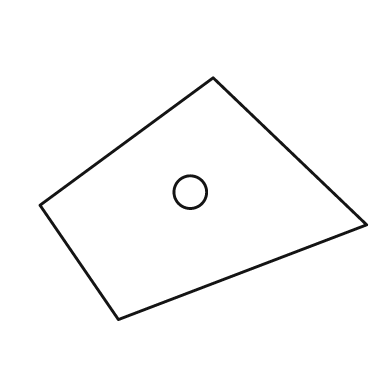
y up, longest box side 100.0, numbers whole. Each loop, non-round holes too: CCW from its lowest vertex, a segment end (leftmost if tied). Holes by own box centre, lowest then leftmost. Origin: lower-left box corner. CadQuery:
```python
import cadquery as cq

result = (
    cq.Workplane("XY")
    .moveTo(24.0, 0.0)
    .lineTo(100.0, 29.0)
    .lineTo(53.0, 74.0)
    .lineTo(0.0, 35.0)
    .close()
    .moveTo(46.0, 39.0)
    .circle(5.0)
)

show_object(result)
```